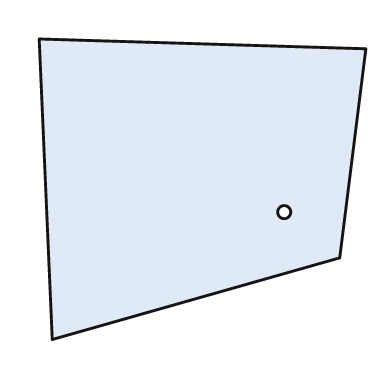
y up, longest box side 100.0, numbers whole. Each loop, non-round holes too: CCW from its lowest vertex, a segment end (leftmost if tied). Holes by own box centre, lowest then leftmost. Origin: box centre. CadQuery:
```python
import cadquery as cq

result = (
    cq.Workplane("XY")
    .moveTo(-46.0, -46.0)
    .lineTo(42.0, -21.0)
    .lineTo(50.0, 43.0)
    .lineTo(-50.0, 46.0)
    .close()
    .moveTo(25.0, -7.0)
    .circle(2.0)
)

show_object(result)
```